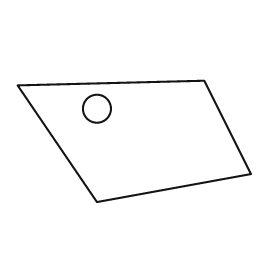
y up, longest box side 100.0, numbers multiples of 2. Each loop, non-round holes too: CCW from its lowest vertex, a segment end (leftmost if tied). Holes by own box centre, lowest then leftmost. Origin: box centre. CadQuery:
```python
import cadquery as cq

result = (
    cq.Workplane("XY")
    .moveTo(-16.0, -26.0)
    .lineTo(50.0, -14.0)
    .lineTo(30.0, 26.0)
    .lineTo(-50.0, 24.0)
    .close()
    .moveTo(-16.0, 14.0)
    .circle(6.0)
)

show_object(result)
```